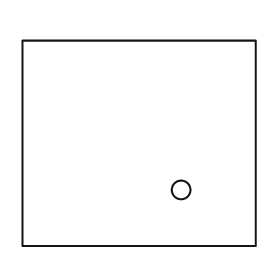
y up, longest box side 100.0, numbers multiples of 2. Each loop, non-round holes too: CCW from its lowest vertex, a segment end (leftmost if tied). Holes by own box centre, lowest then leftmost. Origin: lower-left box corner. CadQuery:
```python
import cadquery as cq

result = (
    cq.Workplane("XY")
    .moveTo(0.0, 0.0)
    .lineTo(100.0, 0.0)
    .lineTo(100.0, 88.0)
    .lineTo(0.0, 88.0)
    .close()
    .moveTo(68.0, 24.0)
    .circle(4.0)
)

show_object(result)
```